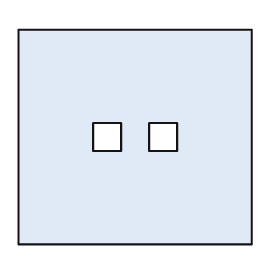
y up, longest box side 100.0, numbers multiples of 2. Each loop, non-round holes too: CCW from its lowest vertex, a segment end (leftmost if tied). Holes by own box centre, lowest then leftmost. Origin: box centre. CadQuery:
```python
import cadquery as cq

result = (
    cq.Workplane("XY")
    .moveTo(-50.0, -46.0)
    .lineTo(50.0, -46.0)
    .lineTo(50.0, 46.0)
    .lineTo(-50.0, 46.0)
    .close()
    .moveTo(-18.0, -6.0)
    .lineTo(-6.0, -6.0)
    .lineTo(-6.0, 6.0)
    .lineTo(-18.0, 6.0)
    .close()
    .moveTo(6.0, -6.0)
    .lineTo(18.0, -6.0)
    .lineTo(18.0, 6.0)
    .lineTo(6.0, 6.0)
    .close()
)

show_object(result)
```